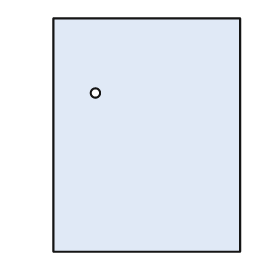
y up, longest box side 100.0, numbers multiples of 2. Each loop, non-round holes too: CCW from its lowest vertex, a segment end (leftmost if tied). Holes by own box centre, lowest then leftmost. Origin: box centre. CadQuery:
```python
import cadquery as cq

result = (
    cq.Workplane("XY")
    .moveTo(-40.0, -50.0)
    .lineTo(40.0, -50.0)
    .lineTo(40.0, 50.0)
    .lineTo(-40.0, 50.0)
    .close()
    .moveTo(-22.0, 18.0)
    .circle(2.0)
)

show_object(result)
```